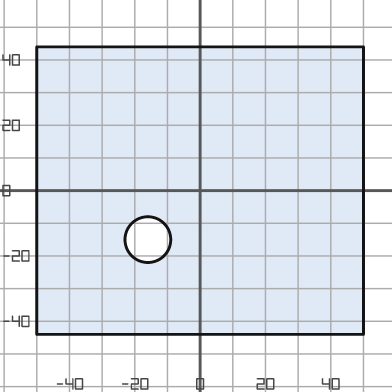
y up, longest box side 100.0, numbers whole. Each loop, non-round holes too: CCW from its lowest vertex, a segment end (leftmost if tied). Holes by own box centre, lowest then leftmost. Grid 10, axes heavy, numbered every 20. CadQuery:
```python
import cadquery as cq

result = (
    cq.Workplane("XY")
    .moveTo(-50.0, -44.0)
    .lineTo(50.0, -44.0)
    .lineTo(50.0, 44.0)
    .lineTo(-50.0, 44.0)
    .close()
    .moveTo(-16.0, -15.0)
    .circle(7.0)
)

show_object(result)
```